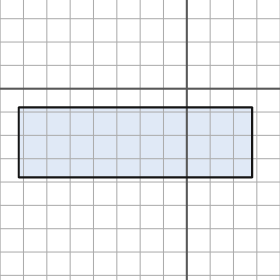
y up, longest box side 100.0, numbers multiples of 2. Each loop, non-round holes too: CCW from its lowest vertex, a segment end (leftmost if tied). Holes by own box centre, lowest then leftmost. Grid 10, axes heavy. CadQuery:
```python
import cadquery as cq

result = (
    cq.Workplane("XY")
    .moveTo(-72.0, -38.0)
    .lineTo(28.0, -38.0)
    .lineTo(28.0, -8.0)
    .lineTo(-72.0, -8.0)
    .close()
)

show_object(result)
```